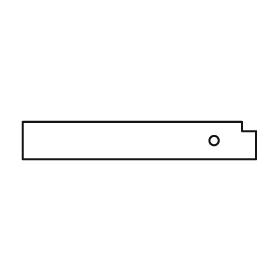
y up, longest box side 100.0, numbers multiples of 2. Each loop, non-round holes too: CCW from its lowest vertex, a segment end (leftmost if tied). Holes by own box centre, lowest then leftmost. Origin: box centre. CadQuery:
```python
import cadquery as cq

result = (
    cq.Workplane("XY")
    .moveTo(-50.0, -8.0)
    .lineTo(50.0, -8.0)
    .lineTo(50.0, 4.0)
    .lineTo(44.0, 4.0)
    .lineTo(44.0, 8.0)
    .lineTo(-50.0, 8.0)
    .close()
    .moveTo(32.0, 0.0)
    .circle(2.0)
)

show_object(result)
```